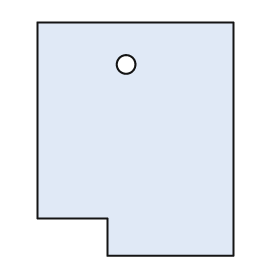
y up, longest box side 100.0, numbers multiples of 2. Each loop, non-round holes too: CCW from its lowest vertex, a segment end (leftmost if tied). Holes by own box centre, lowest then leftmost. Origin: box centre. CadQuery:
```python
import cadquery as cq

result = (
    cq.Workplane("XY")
    .moveTo(-12.0, -50.0)
    .lineTo(42.0, -50.0)
    .lineTo(42.0, 50.0)
    .lineTo(-42.0, 50.0)
    .lineTo(-42.0, -34.0)
    .lineTo(-12.0, -34.0)
    .close()
    .moveTo(-4.0, 32.0)
    .circle(4.0)
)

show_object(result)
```